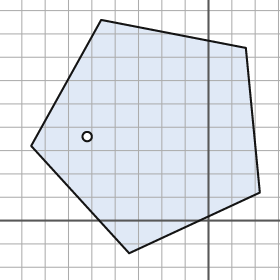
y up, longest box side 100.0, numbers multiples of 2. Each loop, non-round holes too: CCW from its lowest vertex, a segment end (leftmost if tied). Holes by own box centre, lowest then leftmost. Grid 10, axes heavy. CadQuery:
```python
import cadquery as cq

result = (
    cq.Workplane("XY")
    .moveTo(-34.0, -14.0)
    .lineTo(22.0, 12.0)
    .lineTo(16.0, 74.0)
    .lineTo(-46.0, 86.0)
    .lineTo(-76.0, 32.0)
    .close()
    .moveTo(-52.0, 36.0)
    .circle(2.0)
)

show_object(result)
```